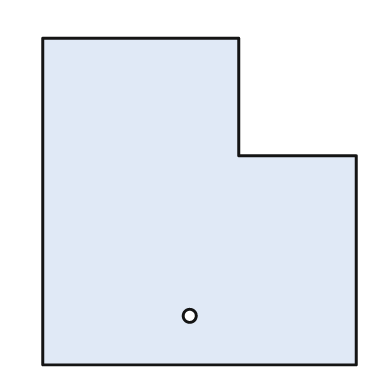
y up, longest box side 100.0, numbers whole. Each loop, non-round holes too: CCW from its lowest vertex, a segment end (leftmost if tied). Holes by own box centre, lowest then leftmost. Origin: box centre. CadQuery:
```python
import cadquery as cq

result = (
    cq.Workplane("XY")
    .moveTo(-48.0, -50.0)
    .lineTo(48.0, -50.0)
    .lineTo(48.0, 14.0)
    .lineTo(12.0, 14.0)
    .lineTo(12.0, 50.0)
    .lineTo(-48.0, 50.0)
    .close()
    .moveTo(-3.0, -35.0)
    .circle(2.0)
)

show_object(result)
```